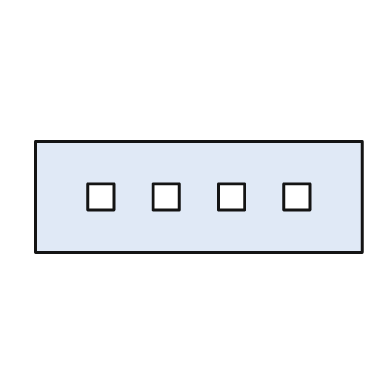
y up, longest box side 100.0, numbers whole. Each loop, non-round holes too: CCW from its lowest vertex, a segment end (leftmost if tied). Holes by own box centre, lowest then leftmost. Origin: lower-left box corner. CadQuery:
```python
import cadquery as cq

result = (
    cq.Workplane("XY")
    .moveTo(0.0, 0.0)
    .lineTo(100.0, 0.0)
    .lineTo(100.0, 34.0)
    .lineTo(0.0, 34.0)
    .close()
    .moveTo(16.0, 13.0)
    .lineTo(24.0, 13.0)
    .lineTo(24.0, 21.0)
    .lineTo(16.0, 21.0)
    .close()
    .moveTo(36.0, 13.0)
    .lineTo(44.0, 13.0)
    .lineTo(44.0, 21.0)
    .lineTo(36.0, 21.0)
    .close()
    .moveTo(56.0, 13.0)
    .lineTo(64.0, 13.0)
    .lineTo(64.0, 21.0)
    .lineTo(56.0, 21.0)
    .close()
    .moveTo(76.0, 13.0)
    .lineTo(84.0, 13.0)
    .lineTo(84.0, 21.0)
    .lineTo(76.0, 21.0)
    .close()
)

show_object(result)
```